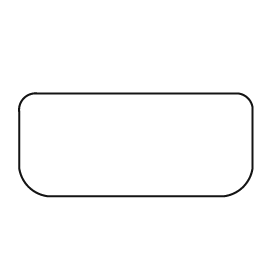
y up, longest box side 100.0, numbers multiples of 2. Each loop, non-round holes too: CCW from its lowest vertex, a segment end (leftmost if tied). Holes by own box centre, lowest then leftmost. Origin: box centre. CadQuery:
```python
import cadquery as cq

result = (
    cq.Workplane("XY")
    .moveTo(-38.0, -22.0)
    .lineTo(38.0, -22.0)
    .threePointArc((46.0, -18.0), (50.0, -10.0))
    .lineTo(50.0, 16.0)
    .threePointArc((48.0, 20.0), (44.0, 22.0))
    .lineTo(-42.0, 22.0)
    .threePointArc((-48.0, 20.0), (-50.0, 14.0))
    .lineTo(-50.0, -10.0)
    .threePointArc((-46.0, -18.0), (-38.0, -22.0))
    .close()
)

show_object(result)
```